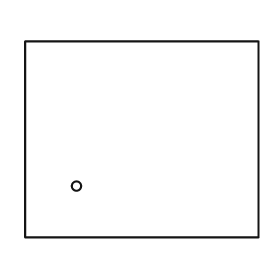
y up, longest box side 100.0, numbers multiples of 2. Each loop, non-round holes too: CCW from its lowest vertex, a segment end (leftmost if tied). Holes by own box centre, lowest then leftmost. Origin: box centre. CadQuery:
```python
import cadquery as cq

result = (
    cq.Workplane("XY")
    .moveTo(-50.0, -42.0)
    .lineTo(50.0, -42.0)
    .lineTo(50.0, 42.0)
    .lineTo(-50.0, 42.0)
    .close()
    .moveTo(-28.0, -20.0)
    .circle(2.0)
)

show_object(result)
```